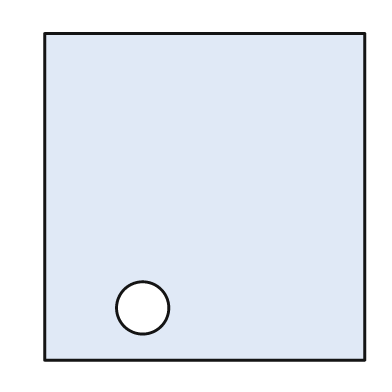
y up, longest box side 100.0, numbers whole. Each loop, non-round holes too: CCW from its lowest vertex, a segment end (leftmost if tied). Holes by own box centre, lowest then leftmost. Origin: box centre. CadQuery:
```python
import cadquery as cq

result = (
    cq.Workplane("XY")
    .moveTo(-49.0, -50.0)
    .lineTo(49.0, -50.0)
    .lineTo(49.0, 50.0)
    .lineTo(-49.0, 50.0)
    .close()
    .moveTo(-19.0, -34.0)
    .circle(8.0)
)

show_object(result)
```